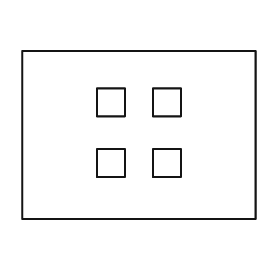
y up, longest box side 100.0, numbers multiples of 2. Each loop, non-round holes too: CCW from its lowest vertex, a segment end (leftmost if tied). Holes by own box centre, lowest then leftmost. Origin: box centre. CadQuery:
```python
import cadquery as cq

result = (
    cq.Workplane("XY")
    .moveTo(-50.0, -36.0)
    .lineTo(50.0, -36.0)
    .lineTo(50.0, 36.0)
    .lineTo(-50.0, 36.0)
    .close()
    .moveTo(-18.0, -18.0)
    .lineTo(-6.0, -18.0)
    .lineTo(-6.0, -6.0)
    .lineTo(-18.0, -6.0)
    .close()
    .moveTo(6.0, -18.0)
    .lineTo(18.0, -18.0)
    .lineTo(18.0, -6.0)
    .lineTo(6.0, -6.0)
    .close()
    .moveTo(-18.0, 8.0)
    .lineTo(-6.0, 8.0)
    .lineTo(-6.0, 20.0)
    .lineTo(-18.0, 20.0)
    .close()
    .moveTo(6.0, 8.0)
    .lineTo(18.0, 8.0)
    .lineTo(18.0, 20.0)
    .lineTo(6.0, 20.0)
    .close()
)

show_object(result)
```